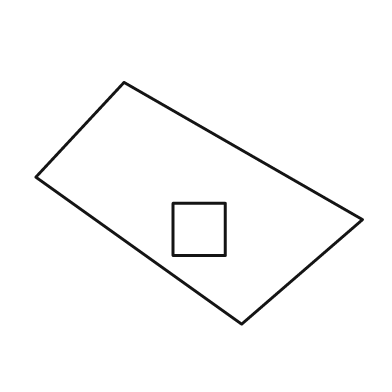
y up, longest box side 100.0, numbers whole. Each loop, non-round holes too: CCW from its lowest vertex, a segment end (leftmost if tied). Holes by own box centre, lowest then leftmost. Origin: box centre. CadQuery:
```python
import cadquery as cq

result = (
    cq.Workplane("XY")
    .moveTo(13.0, -37.0)
    .lineTo(50.0, -5.0)
    .lineTo(-23.0, 37.0)
    .lineTo(-50.0, 8.0)
    .close()
    .moveTo(-8.0, -16.0)
    .lineTo(8.0, -16.0)
    .lineTo(8.0, 0.0)
    .lineTo(-8.0, 0.0)
    .close()
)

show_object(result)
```